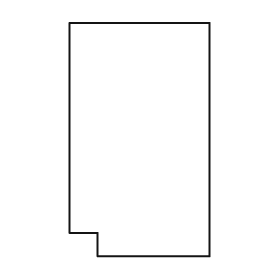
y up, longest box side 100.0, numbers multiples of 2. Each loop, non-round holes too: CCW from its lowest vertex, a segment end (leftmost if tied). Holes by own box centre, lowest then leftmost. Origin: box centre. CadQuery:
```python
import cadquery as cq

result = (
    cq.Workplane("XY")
    .moveTo(-18.0, -50.0)
    .lineTo(30.0, -50.0)
    .lineTo(30.0, 50.0)
    .lineTo(-30.0, 50.0)
    .lineTo(-30.0, -40.0)
    .lineTo(-18.0, -40.0)
    .close()
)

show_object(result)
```